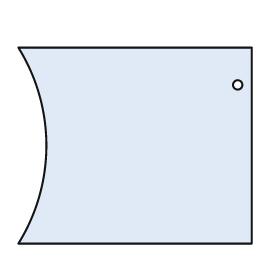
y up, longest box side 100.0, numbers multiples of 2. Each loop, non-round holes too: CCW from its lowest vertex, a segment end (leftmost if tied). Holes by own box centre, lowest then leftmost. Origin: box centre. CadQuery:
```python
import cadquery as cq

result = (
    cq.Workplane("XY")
    .moveTo(-50.0, -42.0)
    .lineTo(50.0, -42.0)
    .lineTo(50.0, 42.0)
    .lineTo(-50.0, 42.0)
    .threePointArc((-38.0, 0.0), (-50.0, -42.0))
    .close()
    .moveTo(44.0, 26.0)
    .circle(2.0)
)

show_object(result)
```